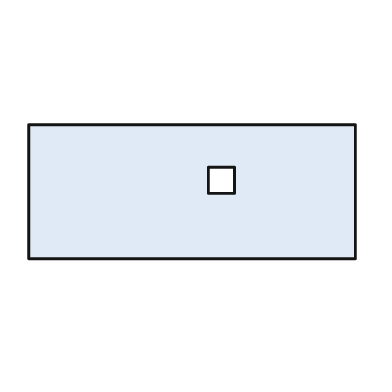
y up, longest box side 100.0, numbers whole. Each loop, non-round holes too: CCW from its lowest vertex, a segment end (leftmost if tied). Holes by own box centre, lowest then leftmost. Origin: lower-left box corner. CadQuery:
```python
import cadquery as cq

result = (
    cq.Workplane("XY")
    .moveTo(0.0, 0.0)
    .lineTo(100.0, 0.0)
    .lineTo(100.0, 41.0)
    .lineTo(0.0, 41.0)
    .close()
    .moveTo(55.0, 20.0)
    .lineTo(63.0, 20.0)
    .lineTo(63.0, 28.0)
    .lineTo(55.0, 28.0)
    .close()
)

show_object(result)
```